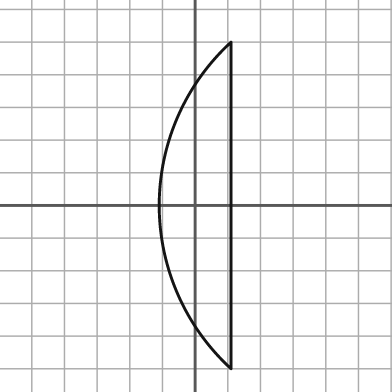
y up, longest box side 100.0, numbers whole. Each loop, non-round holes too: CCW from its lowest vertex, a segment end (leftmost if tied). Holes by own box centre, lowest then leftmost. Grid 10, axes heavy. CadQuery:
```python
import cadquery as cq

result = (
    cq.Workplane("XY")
    .moveTo(11.0, -50.0)
    .lineTo(11.0, 50.0)
    .threePointArc((-11.0, 0.0), (11.0, -50.0))
    .close()
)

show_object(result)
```